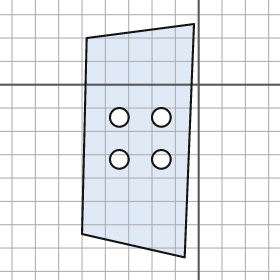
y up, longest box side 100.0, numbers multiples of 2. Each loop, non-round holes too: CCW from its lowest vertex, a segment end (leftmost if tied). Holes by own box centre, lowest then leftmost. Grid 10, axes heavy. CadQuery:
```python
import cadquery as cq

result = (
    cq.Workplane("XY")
    .moveTo(-6.0, -74.0)
    .lineTo(-2.0, 26.0)
    .lineTo(-48.0, 20.0)
    .lineTo(-50.0, -64.0)
    .close()
    .moveTo(-34.0, -32.0)
    .circle(4.0)
    .moveTo(-16.0, -32.0)
    .circle(4.0)
    .moveTo(-34.0, -14.0)
    .circle(4.0)
    .moveTo(-16.0, -14.0)
    .circle(4.0)
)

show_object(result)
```